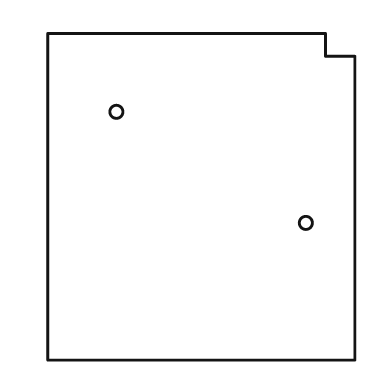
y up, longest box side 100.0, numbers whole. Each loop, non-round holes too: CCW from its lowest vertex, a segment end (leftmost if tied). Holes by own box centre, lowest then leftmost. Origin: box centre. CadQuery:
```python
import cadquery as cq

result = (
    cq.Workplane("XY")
    .moveTo(-47.0, -50.0)
    .lineTo(47.0, -50.0)
    .lineTo(47.0, 43.0)
    .lineTo(38.0, 43.0)
    .lineTo(38.0, 50.0)
    .lineTo(-47.0, 50.0)
    .close()
    .moveTo(32.0, -8.0)
    .circle(2.0)
    .moveTo(-26.0, 26.0)
    .circle(2.0)
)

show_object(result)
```